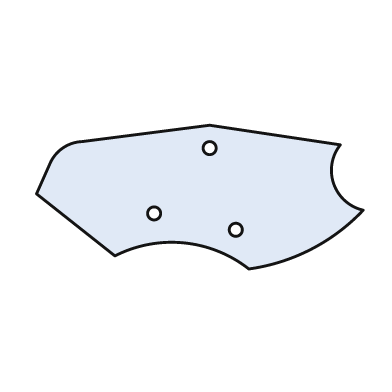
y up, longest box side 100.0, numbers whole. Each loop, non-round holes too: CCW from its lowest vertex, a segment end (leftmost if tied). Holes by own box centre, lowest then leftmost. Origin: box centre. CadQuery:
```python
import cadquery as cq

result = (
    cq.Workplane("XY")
    .moveTo(15.0, -22.0)
    .threePointArc((34.0, -16.0), (50.0, -4.0))
    .threePointArc((41.0, 4.0), (43.0, 16.0))
    .lineTo(3.0, 22.0)
    .lineTo(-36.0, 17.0)
    .threePointArc((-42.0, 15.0), (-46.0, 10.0))
    .lineTo(-50.0, 1.0)
    .lineTo(-26.0, -18.0)
    .threePointArc((-5.0, -14.0), (15.0, -22.0))
    .close()
    .moveTo(11.0, -10.0)
    .circle(2.0)
    .moveTo(-14.0, -5.0)
    .circle(2.0)
    .moveTo(3.0, 15.0)
    .circle(2.0)
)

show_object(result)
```